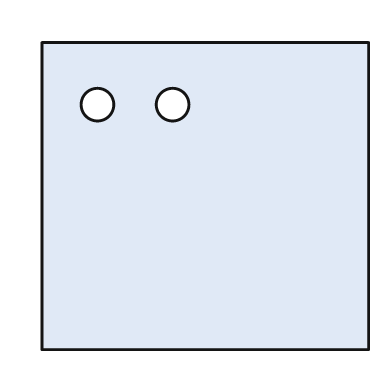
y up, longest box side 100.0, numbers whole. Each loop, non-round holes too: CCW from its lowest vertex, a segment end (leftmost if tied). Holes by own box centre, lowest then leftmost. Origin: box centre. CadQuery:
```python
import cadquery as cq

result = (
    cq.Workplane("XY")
    .moveTo(-50.0, -47.0)
    .lineTo(50.0, -47.0)
    .lineTo(50.0, 47.0)
    .lineTo(-50.0, 47.0)
    .close()
    .moveTo(-33.0, 28.0)
    .circle(5.0)
    .moveTo(-10.0, 28.0)
    .circle(5.0)
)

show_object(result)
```